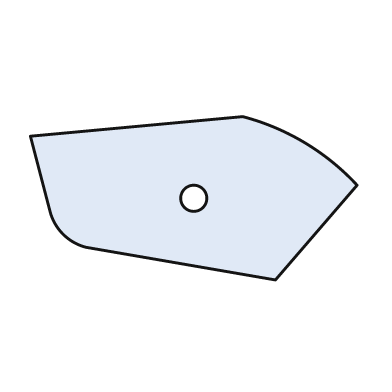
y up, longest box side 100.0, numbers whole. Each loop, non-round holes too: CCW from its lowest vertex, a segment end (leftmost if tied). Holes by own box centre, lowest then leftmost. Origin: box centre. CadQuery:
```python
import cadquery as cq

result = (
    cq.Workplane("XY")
    .moveTo(25.0, -25.0)
    .lineTo(50.0, 4.0)
    .threePointArc((34.0, 17.0), (15.0, 25.0))
    .lineTo(-50.0, 19.0)
    .lineTo(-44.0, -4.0)
    .threePointArc((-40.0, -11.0), (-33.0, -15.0))
    .close()
    .moveTo(0.0, 0.0)
    .circle(4.0)
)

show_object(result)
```